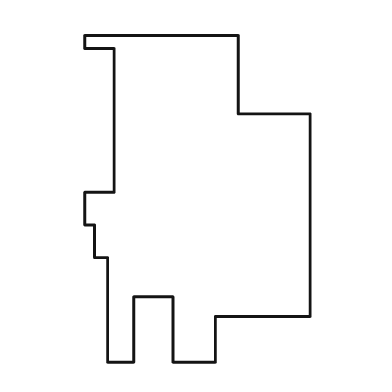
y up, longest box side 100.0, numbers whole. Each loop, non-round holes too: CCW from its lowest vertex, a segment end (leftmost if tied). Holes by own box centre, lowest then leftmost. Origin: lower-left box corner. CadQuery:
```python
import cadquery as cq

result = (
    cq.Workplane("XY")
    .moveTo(7.0, 0.0)
    .lineTo(15.0, 0.0)
    .lineTo(15.0, 20.0)
    .lineTo(27.0, 20.0)
    .lineTo(27.0, 0.0)
    .lineTo(40.0, 0.0)
    .lineTo(40.0, 14.0)
    .lineTo(69.0, 14.0)
    .lineTo(69.0, 76.0)
    .lineTo(47.0, 76.0)
    .lineTo(47.0, 100.0)
    .lineTo(0.0, 100.0)
    .lineTo(0.0, 96.0)
    .lineTo(9.0, 96.0)
    .lineTo(9.0, 52.0)
    .lineTo(0.0, 52.0)
    .lineTo(0.0, 42.0)
    .lineTo(3.0, 42.0)
    .lineTo(3.0, 32.0)
    .lineTo(7.0, 32.0)
    .close()
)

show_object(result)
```